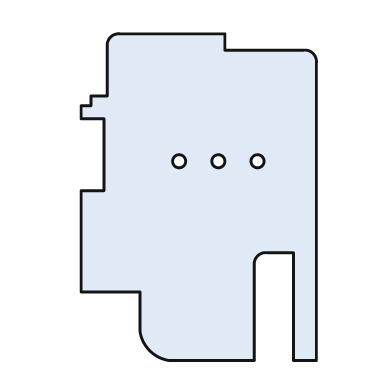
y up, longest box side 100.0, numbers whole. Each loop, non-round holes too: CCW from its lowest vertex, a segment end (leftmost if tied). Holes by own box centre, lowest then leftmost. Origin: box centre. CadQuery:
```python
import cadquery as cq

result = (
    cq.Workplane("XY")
    .moveTo(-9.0, -50.0)
    .lineTo(17.0, -50.0)
    .lineTo(17.0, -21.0)
    .threePointArc((18.0, -18.0), (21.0, -17.0))
    .lineTo(29.0, -17.0)
    .lineTo(29.0, -50.0)
    .lineTo(36.0, -50.0)
    .lineTo(36.0, 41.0)
    .threePointArc((35.0, 44.0), (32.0, 45.0))
    .lineTo(8.0, 45.0)
    .lineTo(8.0, 50.0)
    .lineTo(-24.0, 50.0)
    .threePointArc((-27.0, 49.0), (-28.0, 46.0))
    .lineTo(-28.0, 31.0)
    .lineTo(-33.0, 31.0)
    .lineTo(-33.0, 28.0)
    .lineTo(-36.0, 28.0)
    .lineTo(-36.0, 24.0)
    .lineTo(-29.0, 24.0)
    .lineTo(-29.0, 2.0)
    .lineTo(-36.0, 2.0)
    .lineTo(-36.0, -29.0)
    .lineTo(-18.0, -29.0)
    .lineTo(-18.0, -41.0)
    .threePointArc((-15.0, -47.0), (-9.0, -50.0))
    .close()
    .moveTo(-6.0, 11.0)
    .circle(2.0)
    .moveTo(6.0, 11.0)
    .circle(2.0)
    .moveTo(18.0, 11.0)
    .circle(2.0)
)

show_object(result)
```